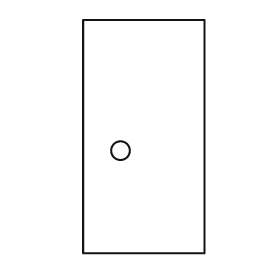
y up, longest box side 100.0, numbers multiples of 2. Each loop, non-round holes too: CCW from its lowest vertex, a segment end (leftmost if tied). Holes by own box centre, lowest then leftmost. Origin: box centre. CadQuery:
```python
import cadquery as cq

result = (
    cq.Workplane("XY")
    .moveTo(-26.0, -50.0)
    .lineTo(26.0, -50.0)
    .lineTo(26.0, 50.0)
    .lineTo(-26.0, 50.0)
    .close()
    .moveTo(-10.0, -6.0)
    .circle(4.0)
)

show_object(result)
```